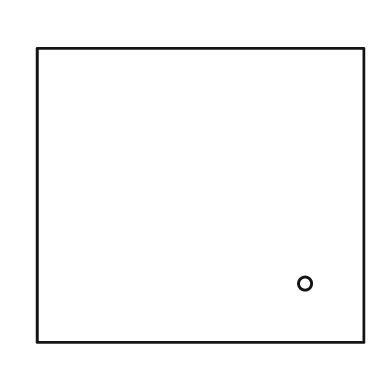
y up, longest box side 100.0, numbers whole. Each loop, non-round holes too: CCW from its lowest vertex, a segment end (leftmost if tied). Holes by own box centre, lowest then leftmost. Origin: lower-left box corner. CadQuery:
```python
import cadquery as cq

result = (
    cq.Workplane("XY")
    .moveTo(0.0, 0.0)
    .lineTo(100.0, 0.0)
    .lineTo(100.0, 90.0)
    .lineTo(0.0, 90.0)
    .close()
    .moveTo(82.0, 18.0)
    .circle(2.0)
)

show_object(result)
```